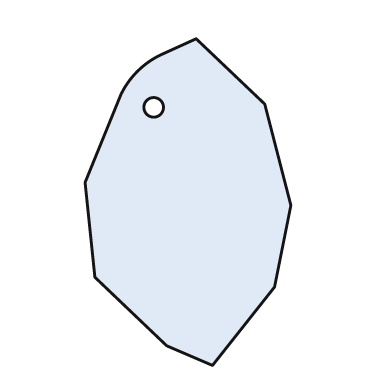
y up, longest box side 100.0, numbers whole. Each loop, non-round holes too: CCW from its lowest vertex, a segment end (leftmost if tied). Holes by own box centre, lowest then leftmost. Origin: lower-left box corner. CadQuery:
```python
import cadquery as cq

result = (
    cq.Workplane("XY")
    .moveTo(39.0, 0.0)
    .lineTo(58.0, 24.0)
    .lineTo(63.0, 49.0)
    .lineTo(55.0, 80.0)
    .lineTo(34.0, 100.0)
    .lineTo(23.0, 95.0)
    .threePointArc((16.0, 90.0), (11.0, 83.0))
    .lineTo(0.0, 56.0)
    .lineTo(3.0, 27.0)
    .lineTo(25.0, 6.0)
    .close()
    .moveTo(21.0, 79.0)
    .circle(3.0)
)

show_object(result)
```